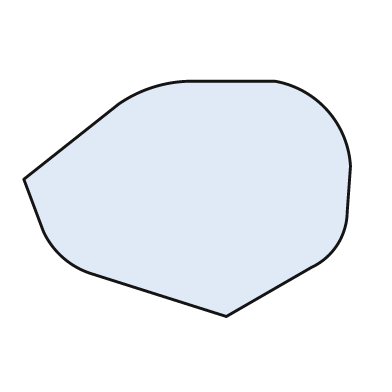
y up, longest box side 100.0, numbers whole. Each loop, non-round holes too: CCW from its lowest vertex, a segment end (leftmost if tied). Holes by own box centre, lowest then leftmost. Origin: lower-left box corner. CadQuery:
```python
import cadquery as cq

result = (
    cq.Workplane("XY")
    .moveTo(62.0, 0.0)
    .lineTo(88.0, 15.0)
    .threePointArc((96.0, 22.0), (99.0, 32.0))
    .lineTo(100.0, 46.0)
    .threePointArc((93.0, 63.0), (77.0, 72.0))
    .lineTo(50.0, 72.0)
    .threePointArc((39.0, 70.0), (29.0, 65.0))
    .lineTo(0.0, 42.0)
    .lineTo(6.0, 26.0)
    .threePointArc((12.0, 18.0), (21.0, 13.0))
    .close()
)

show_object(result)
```